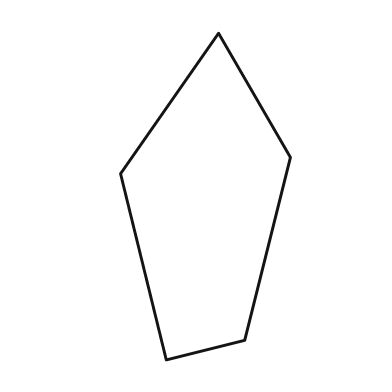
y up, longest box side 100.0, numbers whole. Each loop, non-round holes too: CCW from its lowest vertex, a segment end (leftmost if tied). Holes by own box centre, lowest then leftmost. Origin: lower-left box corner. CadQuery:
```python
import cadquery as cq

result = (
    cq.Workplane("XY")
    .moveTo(14.0, 0.0)
    .lineTo(38.0, 6.0)
    .lineTo(52.0, 62.0)
    .lineTo(30.0, 100.0)
    .lineTo(0.0, 57.0)
    .close()
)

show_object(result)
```